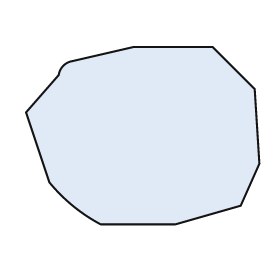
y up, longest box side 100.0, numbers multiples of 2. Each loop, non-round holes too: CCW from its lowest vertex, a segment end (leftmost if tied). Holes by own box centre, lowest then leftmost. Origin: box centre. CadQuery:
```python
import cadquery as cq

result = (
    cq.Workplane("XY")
    .moveTo(-18.0, -38.0)
    .lineTo(14.0, -38.0)
    .lineTo(42.0, -30.0)
    .lineTo(50.0, -12.0)
    .lineTo(48.0, 20.0)
    .lineTo(30.0, 38.0)
    .lineTo(-4.0, 38.0)
    .lineTo(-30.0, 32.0)
    .threePointArc((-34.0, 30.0), (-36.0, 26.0))
    .lineTo(-50.0, 10.0)
    .lineTo(-40.0, -20.0)
    .threePointArc((-30.0, -30.0), (-18.0, -38.0))
    .close()
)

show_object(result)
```